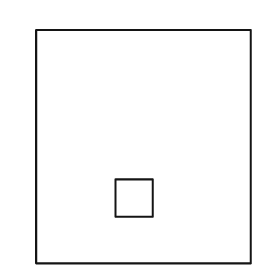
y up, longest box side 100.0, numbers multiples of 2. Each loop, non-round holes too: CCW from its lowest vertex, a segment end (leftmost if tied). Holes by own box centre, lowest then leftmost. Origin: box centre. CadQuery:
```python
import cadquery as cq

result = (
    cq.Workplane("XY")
    .moveTo(-46.0, -50.0)
    .lineTo(46.0, -50.0)
    .lineTo(46.0, 50.0)
    .lineTo(-46.0, 50.0)
    .close()
    .moveTo(-12.0, -30.0)
    .lineTo(4.0, -30.0)
    .lineTo(4.0, -14.0)
    .lineTo(-12.0, -14.0)
    .close()
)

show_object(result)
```